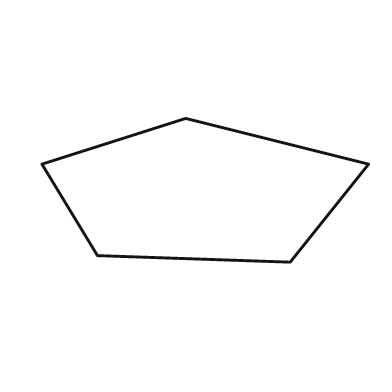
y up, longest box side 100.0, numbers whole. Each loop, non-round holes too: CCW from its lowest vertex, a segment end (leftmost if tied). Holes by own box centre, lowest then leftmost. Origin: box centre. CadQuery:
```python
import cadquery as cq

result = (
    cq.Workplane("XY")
    .moveTo(26.0, -22.0)
    .lineTo(50.0, 8.0)
    .lineTo(-6.0, 22.0)
    .lineTo(-50.0, 8.0)
    .lineTo(-33.0, -20.0)
    .close()
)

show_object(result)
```